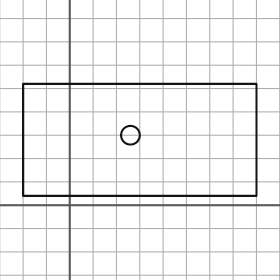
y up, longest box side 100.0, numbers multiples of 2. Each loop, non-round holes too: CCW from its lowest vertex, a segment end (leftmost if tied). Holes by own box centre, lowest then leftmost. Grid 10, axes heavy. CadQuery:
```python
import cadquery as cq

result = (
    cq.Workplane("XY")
    .moveTo(-20.0, 4.0)
    .lineTo(80.0, 4.0)
    .lineTo(80.0, 52.0)
    .lineTo(-20.0, 52.0)
    .close()
    .moveTo(26.0, 30.0)
    .circle(4.0)
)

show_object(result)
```